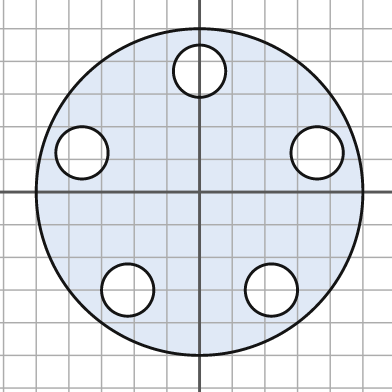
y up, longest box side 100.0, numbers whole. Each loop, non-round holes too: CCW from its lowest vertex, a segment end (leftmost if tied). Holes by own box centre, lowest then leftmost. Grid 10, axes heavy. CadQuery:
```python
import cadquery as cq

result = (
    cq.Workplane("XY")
    .moveTo(0.0, 0.0)
    .circle(50.0)
    .moveTo(-22.0, -30.0)
    .circle(8.0)
    .moveTo(22.0, -30.0)
    .circle(8.0)
    .moveTo(-36.0, 12.0)
    .circle(8.0)
    .moveTo(36.0, 12.0)
    .circle(8.0)
    .moveTo(0.0, 37.0)
    .circle(8.0)
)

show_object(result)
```